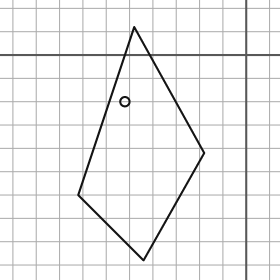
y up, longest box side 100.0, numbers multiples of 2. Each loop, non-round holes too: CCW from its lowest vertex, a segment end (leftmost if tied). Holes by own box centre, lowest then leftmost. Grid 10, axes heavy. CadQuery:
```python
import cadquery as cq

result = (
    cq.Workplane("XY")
    .moveTo(-44.0, -88.0)
    .lineTo(-18.0, -42.0)
    .lineTo(-48.0, 12.0)
    .lineTo(-72.0, -60.0)
    .close()
    .moveTo(-52.0, -20.0)
    .circle(2.0)
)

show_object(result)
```